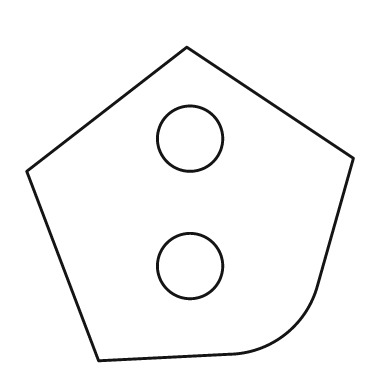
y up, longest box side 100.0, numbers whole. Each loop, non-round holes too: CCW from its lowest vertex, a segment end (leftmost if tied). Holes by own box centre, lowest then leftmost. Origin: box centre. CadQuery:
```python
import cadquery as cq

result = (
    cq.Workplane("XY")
    .moveTo(-28.0, -48.0)
    .lineTo(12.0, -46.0)
    .threePointArc((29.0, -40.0), (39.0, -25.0))
    .lineTo(50.0, 14.0)
    .lineTo(-1.0, 48.0)
    .lineTo(-50.0, 10.0)
    .close()
    .moveTo(0.0, -19.0)
    .circle(10.0)
    .moveTo(0.0, 20.0)
    .circle(10.0)
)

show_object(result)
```